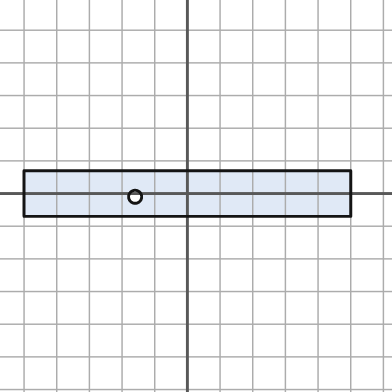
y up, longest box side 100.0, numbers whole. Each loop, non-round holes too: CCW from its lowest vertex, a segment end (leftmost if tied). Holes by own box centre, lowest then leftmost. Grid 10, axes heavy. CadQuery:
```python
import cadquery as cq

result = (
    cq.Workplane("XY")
    .moveTo(-50.0, -7.0)
    .lineTo(50.0, -7.0)
    .lineTo(50.0, 7.0)
    .lineTo(-50.0, 7.0)
    .close()
    .moveTo(-16.0, -1.0)
    .circle(2.0)
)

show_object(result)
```